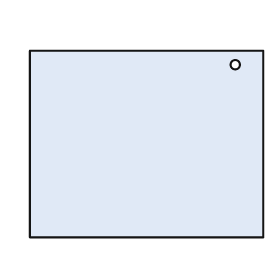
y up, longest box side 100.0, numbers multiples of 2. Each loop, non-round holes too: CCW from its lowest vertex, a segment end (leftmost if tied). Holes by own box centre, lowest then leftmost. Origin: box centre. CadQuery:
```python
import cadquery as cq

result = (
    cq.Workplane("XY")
    .moveTo(-50.0, -40.0)
    .lineTo(50.0, -40.0)
    .lineTo(50.0, 40.0)
    .lineTo(-50.0, 40.0)
    .close()
    .moveTo(38.0, 34.0)
    .circle(2.0)
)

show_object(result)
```